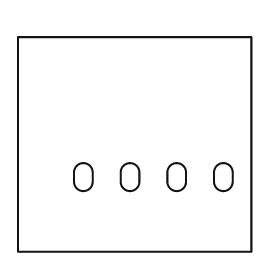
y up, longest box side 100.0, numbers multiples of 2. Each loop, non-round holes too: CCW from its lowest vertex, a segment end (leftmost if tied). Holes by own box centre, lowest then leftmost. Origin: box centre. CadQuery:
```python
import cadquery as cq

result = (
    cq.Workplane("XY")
    .moveTo(-50.0, -46.0)
    .lineTo(50.0, -46.0)
    .lineTo(50.0, 46.0)
    .lineTo(-50.0, 46.0)
    .close()
    .moveTo(-26.0, -16.0)
    .threePointArc((-22.0, -20.0), (-18.0, -16.0))
    .lineTo(-18.0, -12.0)
    .threePointArc((-22.0, -8.0), (-26.0, -12.0))
    .close()
    .moveTo(-6.0, -16.0)
    .threePointArc((-2.0, -20.0), (2.0, -16.0))
    .lineTo(2.0, -12.0)
    .threePointArc((-2.0, -8.0), (-6.0, -12.0))
    .close()
    .moveTo(14.0, -16.0)
    .threePointArc((18.0, -20.0), (22.0, -16.0))
    .lineTo(22.0, -12.0)
    .threePointArc((18.0, -8.0), (14.0, -12.0))
    .close()
    .moveTo(34.0, -16.0)
    .threePointArc((38.0, -20.0), (42.0, -16.0))
    .lineTo(42.0, -12.0)
    .threePointArc((38.0, -8.0), (34.0, -12.0))
    .close()
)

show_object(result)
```